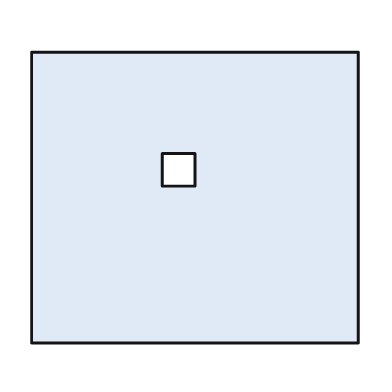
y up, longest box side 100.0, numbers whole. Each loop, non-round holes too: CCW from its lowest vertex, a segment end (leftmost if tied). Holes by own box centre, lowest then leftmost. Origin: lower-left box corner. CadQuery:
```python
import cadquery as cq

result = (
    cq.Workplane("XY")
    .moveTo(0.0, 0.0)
    .lineTo(100.0, 0.0)
    .lineTo(100.0, 89.0)
    .lineTo(0.0, 89.0)
    .close()
    .moveTo(40.0, 48.0)
    .lineTo(50.0, 48.0)
    .lineTo(50.0, 58.0)
    .lineTo(40.0, 58.0)
    .close()
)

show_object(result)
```